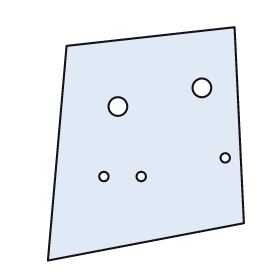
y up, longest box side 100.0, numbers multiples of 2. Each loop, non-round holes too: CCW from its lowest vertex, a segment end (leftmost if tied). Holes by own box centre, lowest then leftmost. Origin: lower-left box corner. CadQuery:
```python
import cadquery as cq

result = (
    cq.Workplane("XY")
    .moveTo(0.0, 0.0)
    .lineTo(84.0, 16.0)
    .lineTo(80.0, 100.0)
    .lineTo(8.0, 92.0)
    .close()
    .moveTo(24.0, 36.0)
    .circle(2.0)
    .moveTo(40.0, 36.0)
    .circle(2.0)
    .moveTo(76.0, 44.0)
    .circle(2.0)
    .moveTo(30.0, 66.0)
    .circle(4.0)
    .moveTo(66.0, 74.0)
    .circle(4.0)
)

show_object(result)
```